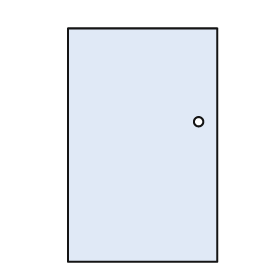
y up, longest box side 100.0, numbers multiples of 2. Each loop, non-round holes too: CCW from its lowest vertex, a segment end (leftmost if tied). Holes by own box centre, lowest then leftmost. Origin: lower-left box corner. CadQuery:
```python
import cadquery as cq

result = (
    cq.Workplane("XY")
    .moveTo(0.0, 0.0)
    .lineTo(64.0, 0.0)
    .lineTo(64.0, 100.0)
    .lineTo(0.0, 100.0)
    .close()
    .moveTo(56.0, 60.0)
    .circle(2.0)
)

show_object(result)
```